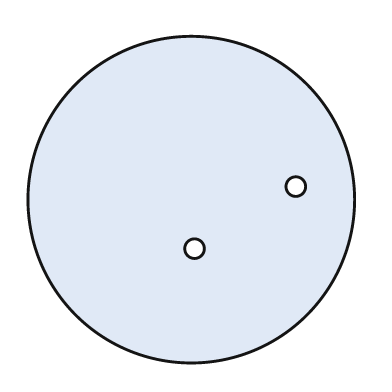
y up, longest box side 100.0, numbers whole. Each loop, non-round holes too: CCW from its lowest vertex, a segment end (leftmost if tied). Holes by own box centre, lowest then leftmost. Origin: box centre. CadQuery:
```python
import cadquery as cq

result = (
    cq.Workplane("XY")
    .moveTo(0.0, 0.0)
    .circle(50.0)
    .moveTo(1.0, -15.0)
    .circle(3.0)
    .moveTo(32.0, 4.0)
    .circle(3.0)
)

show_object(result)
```